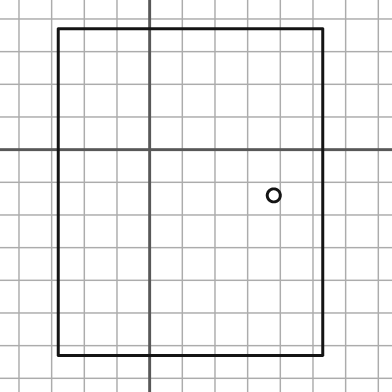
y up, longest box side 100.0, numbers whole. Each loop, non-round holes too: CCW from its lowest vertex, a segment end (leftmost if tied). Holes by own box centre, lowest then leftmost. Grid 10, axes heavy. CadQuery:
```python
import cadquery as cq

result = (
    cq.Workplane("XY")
    .moveTo(-28.0, -63.0)
    .lineTo(53.0, -63.0)
    .lineTo(53.0, 37.0)
    .lineTo(-28.0, 37.0)
    .close()
    .moveTo(38.0, -14.0)
    .circle(2.0)
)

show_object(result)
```